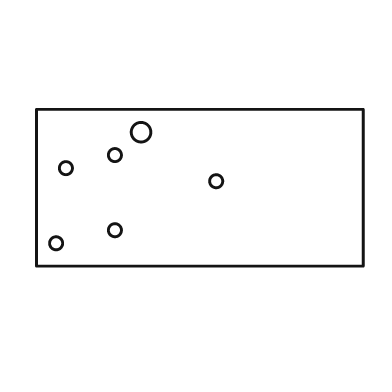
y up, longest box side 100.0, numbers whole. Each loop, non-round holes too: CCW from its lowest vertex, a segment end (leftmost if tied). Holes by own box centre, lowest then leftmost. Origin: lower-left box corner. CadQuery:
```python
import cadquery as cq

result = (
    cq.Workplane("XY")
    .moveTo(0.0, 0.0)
    .lineTo(100.0, 0.0)
    .lineTo(100.0, 48.0)
    .lineTo(0.0, 48.0)
    .close()
    .moveTo(6.0, 7.0)
    .circle(2.0)
    .moveTo(24.0, 11.0)
    .circle(2.0)
    .moveTo(55.0, 26.0)
    .circle(2.0)
    .moveTo(9.0, 30.0)
    .circle(2.0)
    .moveTo(24.0, 34.0)
    .circle(2.0)
    .moveTo(32.0, 41.0)
    .circle(3.0)
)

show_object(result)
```